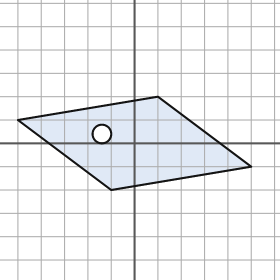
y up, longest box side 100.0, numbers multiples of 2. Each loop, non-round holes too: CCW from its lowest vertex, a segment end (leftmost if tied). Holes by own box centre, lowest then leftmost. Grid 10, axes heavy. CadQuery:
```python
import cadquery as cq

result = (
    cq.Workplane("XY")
    .moveTo(-10.0, -20.0)
    .lineTo(50.0, -10.0)
    .lineTo(10.0, 20.0)
    .lineTo(-50.0, 10.0)
    .close()
    .moveTo(-14.0, 4.0)
    .circle(4.0)
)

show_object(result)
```